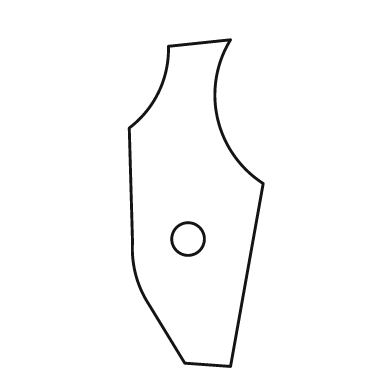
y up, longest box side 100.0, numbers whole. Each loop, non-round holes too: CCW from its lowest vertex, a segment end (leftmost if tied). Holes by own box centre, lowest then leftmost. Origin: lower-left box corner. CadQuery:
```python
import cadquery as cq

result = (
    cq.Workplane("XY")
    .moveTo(31.0, 0.0)
    .lineTo(41.0, 56.0)
    .threePointArc((27.0, 76.0), (31.0, 100.0))
    .lineTo(12.0, 98.0)
    .threePointArc((9.0, 84.0), (0.0, 73.0))
    .lineTo(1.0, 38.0)
    .threePointArc((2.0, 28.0), (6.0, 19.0))
    .lineTo(17.0, 1.0)
    .close()
    .moveTo(18.0, 39.0)
    .circle(5.0)
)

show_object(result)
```